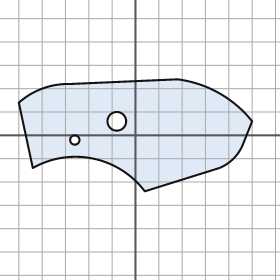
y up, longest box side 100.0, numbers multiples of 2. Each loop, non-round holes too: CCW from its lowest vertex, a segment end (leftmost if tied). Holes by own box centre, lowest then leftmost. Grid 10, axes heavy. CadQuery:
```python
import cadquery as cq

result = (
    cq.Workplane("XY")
    .moveTo(4.0, -24.0)
    .lineTo(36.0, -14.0)
    .threePointArc((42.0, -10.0), (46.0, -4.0))
    .lineTo(50.0, 6.0)
    .threePointArc((36.0, 18.0), (18.0, 24.0))
    .lineTo(-28.0, 22.0)
    .threePointArc((-40.0, 20.0), (-50.0, 14.0))
    .lineTo(-44.0, -14.0)
    .threePointArc((-18.0, -10.0), (4.0, -24.0))
    .close()
    .moveTo(-26.0, -2.0)
    .circle(2.0)
    .moveTo(-8.0, 6.0)
    .circle(4.0)
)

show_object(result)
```